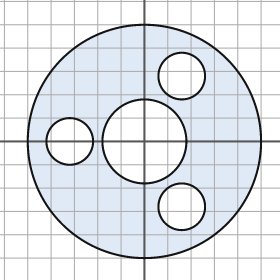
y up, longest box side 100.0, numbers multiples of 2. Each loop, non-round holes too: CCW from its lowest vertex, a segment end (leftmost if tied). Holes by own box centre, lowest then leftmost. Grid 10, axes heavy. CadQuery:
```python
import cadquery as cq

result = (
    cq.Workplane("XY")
    .moveTo(0.0, 0.0)
    .circle(50.0)
    .moveTo(16.0, -28.0)
    .circle(10.0)
    .moveTo(-32.0, 0.0)
    .circle(10.0)
    .moveTo(0.0, 0.0)
    .circle(18.0)
    .moveTo(16.0, 28.0)
    .circle(10.0)
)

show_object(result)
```